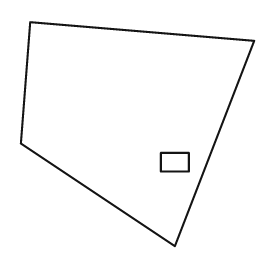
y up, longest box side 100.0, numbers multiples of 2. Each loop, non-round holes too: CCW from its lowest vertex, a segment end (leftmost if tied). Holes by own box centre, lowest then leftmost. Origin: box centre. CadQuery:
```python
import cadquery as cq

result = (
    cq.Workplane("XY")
    .moveTo(16.0, -48.0)
    .lineTo(50.0, 40.0)
    .lineTo(-46.0, 48.0)
    .lineTo(-50.0, -4.0)
    .close()
    .moveTo(10.0, -16.0)
    .lineTo(22.0, -16.0)
    .lineTo(22.0, -8.0)
    .lineTo(10.0, -8.0)
    .close()
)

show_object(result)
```